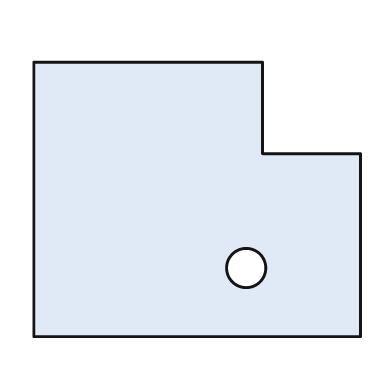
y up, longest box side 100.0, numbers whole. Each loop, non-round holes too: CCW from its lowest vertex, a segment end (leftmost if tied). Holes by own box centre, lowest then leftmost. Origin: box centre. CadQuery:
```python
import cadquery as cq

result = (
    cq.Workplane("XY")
    .moveTo(-50.0, -42.0)
    .lineTo(50.0, -42.0)
    .lineTo(50.0, 14.0)
    .lineTo(20.0, 14.0)
    .lineTo(20.0, 42.0)
    .lineTo(-50.0, 42.0)
    .close()
    .moveTo(15.0, -21.0)
    .circle(6.0)
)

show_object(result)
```